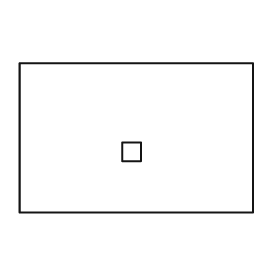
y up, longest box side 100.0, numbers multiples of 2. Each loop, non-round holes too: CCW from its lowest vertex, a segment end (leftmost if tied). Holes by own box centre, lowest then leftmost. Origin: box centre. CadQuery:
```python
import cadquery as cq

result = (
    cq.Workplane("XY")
    .moveTo(-50.0, -32.0)
    .lineTo(50.0, -32.0)
    .lineTo(50.0, 32.0)
    .lineTo(-50.0, 32.0)
    .close()
    .moveTo(-6.0, -10.0)
    .lineTo(2.0, -10.0)
    .lineTo(2.0, -2.0)
    .lineTo(-6.0, -2.0)
    .close()
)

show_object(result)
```